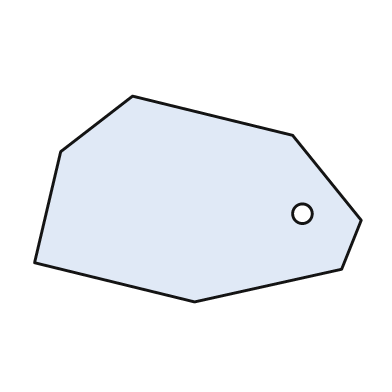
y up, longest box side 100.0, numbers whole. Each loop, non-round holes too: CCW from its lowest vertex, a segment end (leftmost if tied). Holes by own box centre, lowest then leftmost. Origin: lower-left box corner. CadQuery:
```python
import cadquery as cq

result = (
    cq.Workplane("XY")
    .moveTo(49.0, 0.0)
    .lineTo(94.0, 10.0)
    .lineTo(100.0, 25.0)
    .lineTo(79.0, 51.0)
    .lineTo(30.0, 63.0)
    .lineTo(8.0, 46.0)
    .lineTo(0.0, 12.0)
    .close()
    .moveTo(82.0, 27.0)
    .circle(3.0)
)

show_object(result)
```